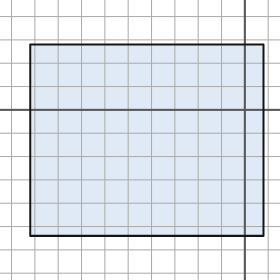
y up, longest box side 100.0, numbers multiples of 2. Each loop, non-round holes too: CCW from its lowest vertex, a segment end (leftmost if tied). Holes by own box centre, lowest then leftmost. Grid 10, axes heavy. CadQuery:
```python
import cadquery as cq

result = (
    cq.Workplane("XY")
    .moveTo(-92.0, -54.0)
    .lineTo(8.0, -54.0)
    .lineTo(8.0, 28.0)
    .lineTo(-92.0, 28.0)
    .close()
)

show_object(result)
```